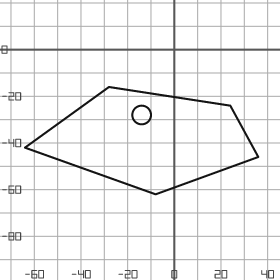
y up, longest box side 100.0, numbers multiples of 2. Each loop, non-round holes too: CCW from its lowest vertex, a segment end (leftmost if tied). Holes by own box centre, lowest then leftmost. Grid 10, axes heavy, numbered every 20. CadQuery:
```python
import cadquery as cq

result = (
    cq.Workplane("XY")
    .moveTo(-8.0, -62.0)
    .lineTo(36.0, -46.0)
    .lineTo(24.0, -24.0)
    .lineTo(-28.0, -16.0)
    .lineTo(-64.0, -42.0)
    .close()
    .moveTo(-14.0, -28.0)
    .circle(4.0)
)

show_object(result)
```